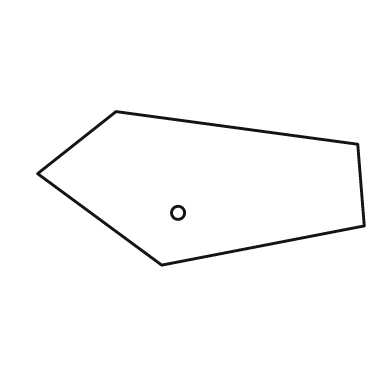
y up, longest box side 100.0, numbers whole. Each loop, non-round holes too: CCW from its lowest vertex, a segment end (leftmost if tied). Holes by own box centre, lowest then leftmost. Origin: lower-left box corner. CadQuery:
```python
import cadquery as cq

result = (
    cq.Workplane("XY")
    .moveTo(38.0, 0.0)
    .lineTo(100.0, 12.0)
    .lineTo(98.0, 37.0)
    .lineTo(24.0, 47.0)
    .lineTo(0.0, 28.0)
    .close()
    .moveTo(43.0, 16.0)
    .circle(2.0)
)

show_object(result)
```